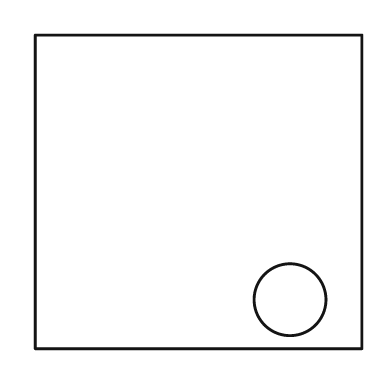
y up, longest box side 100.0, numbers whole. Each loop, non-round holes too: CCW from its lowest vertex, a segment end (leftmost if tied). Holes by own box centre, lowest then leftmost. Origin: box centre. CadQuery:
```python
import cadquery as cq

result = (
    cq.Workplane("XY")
    .moveTo(-50.0, -48.0)
    .lineTo(50.0, -48.0)
    .lineTo(50.0, 48.0)
    .lineTo(-50.0, 48.0)
    .close()
    .moveTo(28.0, -33.0)
    .circle(11.0)
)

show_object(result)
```